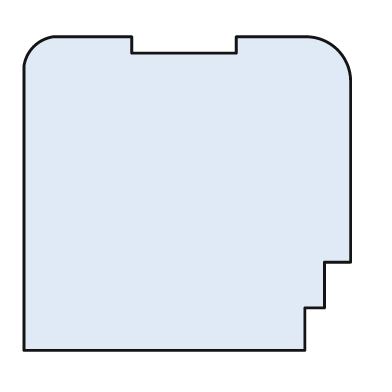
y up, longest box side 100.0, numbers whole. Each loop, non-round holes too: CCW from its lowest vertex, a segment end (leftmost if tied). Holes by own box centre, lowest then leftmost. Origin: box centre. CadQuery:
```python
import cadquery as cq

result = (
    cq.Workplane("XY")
    .moveTo(-50.0, -48.0)
    .lineTo(36.0, -48.0)
    .lineTo(36.0, -35.0)
    .lineTo(42.0, -35.0)
    .lineTo(42.0, -21.0)
    .lineTo(50.0, -21.0)
    .lineTo(50.0, 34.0)
    .threePointArc((46.0, 44.0), (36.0, 48.0))
    .lineTo(15.0, 48.0)
    .lineTo(15.0, 43.0)
    .lineTo(-17.0, 43.0)
    .lineTo(-17.0, 48.0)
    .lineTo(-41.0, 48.0)
    .threePointArc((-47.0, 45.0), (-50.0, 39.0))
    .close()
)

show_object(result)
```